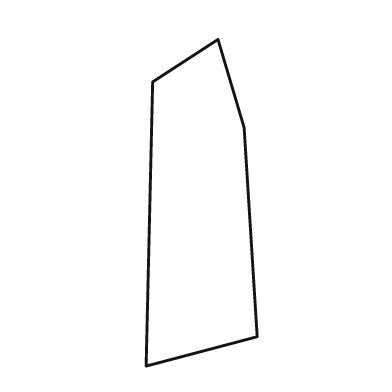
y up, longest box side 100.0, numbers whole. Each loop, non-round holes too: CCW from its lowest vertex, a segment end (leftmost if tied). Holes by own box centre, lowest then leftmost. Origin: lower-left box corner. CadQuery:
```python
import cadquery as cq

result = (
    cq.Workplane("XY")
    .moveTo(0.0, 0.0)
    .lineTo(34.0, 9.0)
    .lineTo(30.0, 73.0)
    .lineTo(22.0, 100.0)
    .lineTo(2.0, 87.0)
    .close()
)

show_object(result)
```